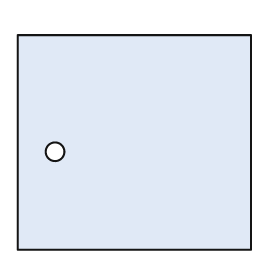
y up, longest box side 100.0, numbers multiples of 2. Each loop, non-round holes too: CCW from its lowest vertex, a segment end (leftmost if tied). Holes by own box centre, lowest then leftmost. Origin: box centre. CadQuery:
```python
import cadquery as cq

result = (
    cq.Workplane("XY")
    .moveTo(-50.0, -46.0)
    .lineTo(50.0, -46.0)
    .lineTo(50.0, 46.0)
    .lineTo(-50.0, 46.0)
    .close()
    .moveTo(-34.0, -4.0)
    .circle(4.0)
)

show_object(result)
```